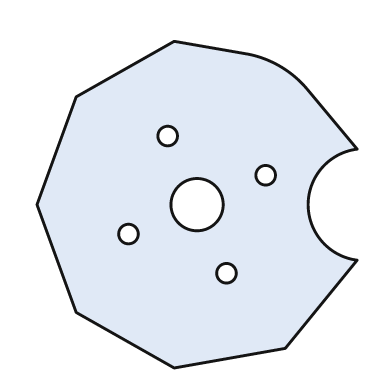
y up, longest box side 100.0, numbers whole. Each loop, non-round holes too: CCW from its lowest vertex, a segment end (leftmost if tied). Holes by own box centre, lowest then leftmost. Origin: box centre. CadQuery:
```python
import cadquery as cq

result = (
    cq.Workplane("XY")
    .moveTo(-7.0, -50.0)
    .lineTo(27.0, -44.0)
    .lineTo(49.0, -17.0)
    .threePointArc((34.0, 0.0), (49.0, 17.0))
    .lineTo(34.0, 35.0)
    .threePointArc((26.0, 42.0), (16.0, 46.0))
    .lineTo(-7.0, 50.0)
    .lineTo(-37.0, 33.0)
    .lineTo(-49.0, 0.0)
    .lineTo(-37.0, -33.0)
    .close()
    .moveTo(9.0, -21.0)
    .circle(3.0)
    .moveTo(-21.0, -9.0)
    .circle(3.0)
    .moveTo(0.0, 0.0)
    .circle(8.0)
    .moveTo(21.0, 9.0)
    .circle(3.0)
    .moveTo(-9.0, 21.0)
    .circle(3.0)
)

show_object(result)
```